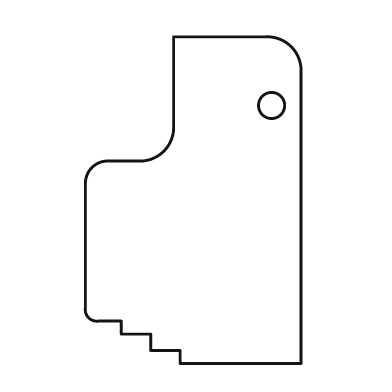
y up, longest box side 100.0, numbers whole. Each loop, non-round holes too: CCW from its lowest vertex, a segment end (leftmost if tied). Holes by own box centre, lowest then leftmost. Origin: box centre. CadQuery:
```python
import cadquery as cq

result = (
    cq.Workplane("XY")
    .moveTo(-4.0, -50.0)
    .lineTo(33.0, -50.0)
    .lineTo(33.0, 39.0)
    .threePointArc((30.0, 47.0), (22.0, 50.0))
    .lineTo(-6.0, 50.0)
    .lineTo(-6.0, 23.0)
    .threePointArc((-9.0, 15.0), (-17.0, 12.0))
    .lineTo(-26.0, 12.0)
    .threePointArc((-31.0, 10.0), (-33.0, 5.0))
    .lineTo(-33.0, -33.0)
    .threePointArc((-32.0, -36.0), (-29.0, -37.0))
    .lineTo(-22.0, -37.0)
    .lineTo(-22.0, -41.0)
    .lineTo(-13.0, -41.0)
    .lineTo(-13.0, -46.0)
    .lineTo(-4.0, -46.0)
    .close()
    .moveTo(24.0, 29.0)
    .circle(4.0)
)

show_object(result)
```